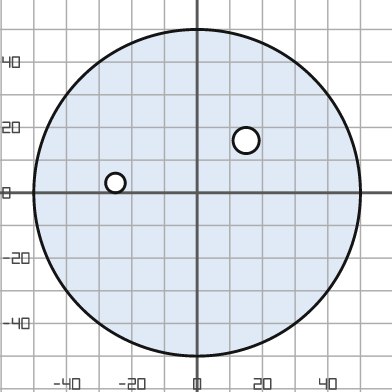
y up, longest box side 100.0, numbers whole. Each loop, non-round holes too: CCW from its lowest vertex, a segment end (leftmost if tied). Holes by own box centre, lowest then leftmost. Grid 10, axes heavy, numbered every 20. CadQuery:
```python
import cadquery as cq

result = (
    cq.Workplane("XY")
    .moveTo(0.0, 0.0)
    .circle(50.0)
    .moveTo(-25.0, 3.0)
    .circle(3.0)
    .moveTo(15.0, 16.0)
    .circle(4.0)
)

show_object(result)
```